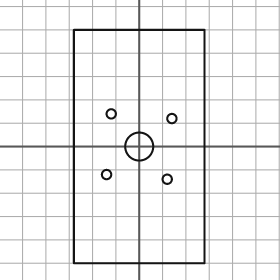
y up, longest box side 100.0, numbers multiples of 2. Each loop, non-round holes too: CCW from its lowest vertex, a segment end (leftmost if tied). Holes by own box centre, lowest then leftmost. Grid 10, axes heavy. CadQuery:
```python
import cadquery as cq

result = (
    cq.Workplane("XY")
    .moveTo(-28.0, -50.0)
    .lineTo(28.0, -50.0)
    .lineTo(28.0, 50.0)
    .lineTo(-28.0, 50.0)
    .close()
    .moveTo(12.0, -14.0)
    .circle(2.0)
    .moveTo(-14.0, -12.0)
    .circle(2.0)
    .moveTo(0.0, 0.0)
    .circle(6.0)
    .moveTo(14.0, 12.0)
    .circle(2.0)
    .moveTo(-12.0, 14.0)
    .circle(2.0)
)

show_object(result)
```